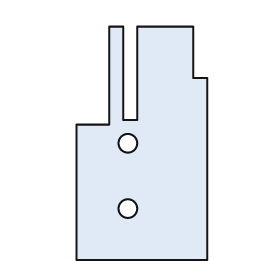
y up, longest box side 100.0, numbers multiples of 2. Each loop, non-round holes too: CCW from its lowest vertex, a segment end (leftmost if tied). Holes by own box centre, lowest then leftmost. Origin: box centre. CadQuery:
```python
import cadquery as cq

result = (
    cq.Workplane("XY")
    .moveTo(-28.0, -50.0)
    .lineTo(28.0, -50.0)
    .lineTo(28.0, 28.0)
    .lineTo(22.0, 28.0)
    .lineTo(22.0, 50.0)
    .lineTo(-2.0, 50.0)
    .lineTo(-2.0, 10.0)
    .lineTo(-8.0, 10.0)
    .lineTo(-8.0, 50.0)
    .lineTo(-14.0, 50.0)
    .lineTo(-14.0, 8.0)
    .lineTo(-28.0, 8.0)
    .close()
    .moveTo(-6.0, -28.0)
    .circle(4.0)
    .moveTo(-6.0, 0.0)
    .circle(4.0)
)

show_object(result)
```